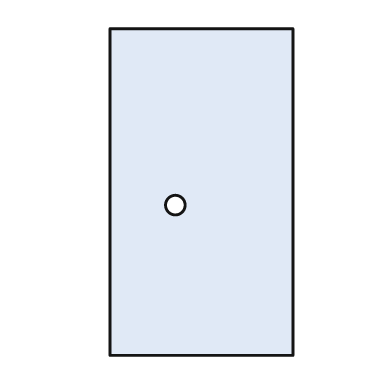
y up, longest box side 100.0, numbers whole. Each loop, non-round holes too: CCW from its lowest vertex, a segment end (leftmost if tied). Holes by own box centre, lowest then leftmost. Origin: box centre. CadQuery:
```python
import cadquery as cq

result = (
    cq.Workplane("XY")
    .moveTo(-28.0, -50.0)
    .lineTo(28.0, -50.0)
    .lineTo(28.0, 50.0)
    .lineTo(-28.0, 50.0)
    .close()
    .moveTo(-8.0, -4.0)
    .circle(3.0)
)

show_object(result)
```